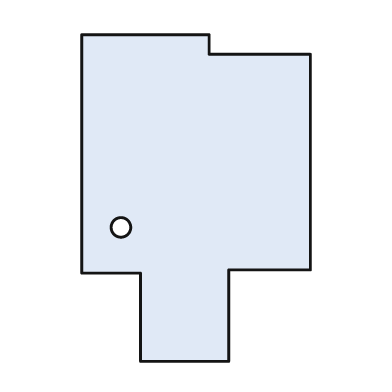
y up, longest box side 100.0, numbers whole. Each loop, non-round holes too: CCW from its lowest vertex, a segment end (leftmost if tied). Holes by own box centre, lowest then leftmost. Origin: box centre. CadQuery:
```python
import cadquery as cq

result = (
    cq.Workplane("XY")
    .moveTo(-17.0, -50.0)
    .lineTo(10.0, -50.0)
    .lineTo(10.0, -22.0)
    .lineTo(35.0, -22.0)
    .lineTo(35.0, 44.0)
    .lineTo(4.0, 44.0)
    .lineTo(4.0, 50.0)
    .lineTo(-35.0, 50.0)
    .lineTo(-35.0, -23.0)
    .lineTo(-17.0, -23.0)
    .close()
    .moveTo(-23.0, -9.0)
    .circle(3.0)
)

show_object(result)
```